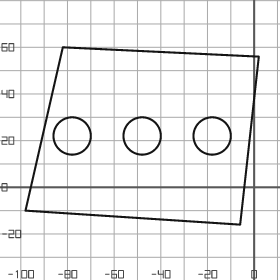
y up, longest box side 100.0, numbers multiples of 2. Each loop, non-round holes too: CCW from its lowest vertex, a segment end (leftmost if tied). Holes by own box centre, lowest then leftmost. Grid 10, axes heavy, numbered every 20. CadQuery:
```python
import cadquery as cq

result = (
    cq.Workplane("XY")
    .moveTo(-6.0, -16.0)
    .lineTo(2.0, 56.0)
    .lineTo(-82.0, 60.0)
    .lineTo(-98.0, -10.0)
    .close()
    .moveTo(-78.0, 22.0)
    .circle(8.0)
    .moveTo(-48.0, 22.0)
    .circle(8.0)
    .moveTo(-18.0, 22.0)
    .circle(8.0)
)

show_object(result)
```